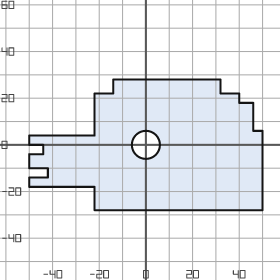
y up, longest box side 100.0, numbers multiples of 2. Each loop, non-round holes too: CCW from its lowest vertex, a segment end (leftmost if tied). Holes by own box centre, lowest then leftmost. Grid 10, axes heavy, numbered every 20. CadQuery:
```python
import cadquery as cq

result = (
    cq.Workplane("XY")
    .moveTo(-22.0, -28.0)
    .lineTo(50.0, -28.0)
    .lineTo(50.0, 6.0)
    .lineTo(46.0, 6.0)
    .lineTo(46.0, 18.0)
    .lineTo(40.0, 18.0)
    .lineTo(40.0, 22.0)
    .lineTo(32.0, 22.0)
    .lineTo(32.0, 28.0)
    .lineTo(-14.0, 28.0)
    .lineTo(-14.0, 22.0)
    .lineTo(-22.0, 22.0)
    .lineTo(-22.0, 4.0)
    .lineTo(-50.0, 4.0)
    .lineTo(-50.0, 0.0)
    .lineTo(-44.0, 0.0)
    .lineTo(-44.0, -4.0)
    .lineTo(-50.0, -4.0)
    .lineTo(-50.0, -10.0)
    .lineTo(-42.0, -10.0)
    .lineTo(-42.0, -14.0)
    .lineTo(-50.0, -14.0)
    .lineTo(-50.0, -18.0)
    .lineTo(-22.0, -18.0)
    .close()
    .moveTo(0.0, 0.0)
    .circle(6.0)
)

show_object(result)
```